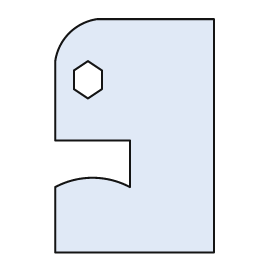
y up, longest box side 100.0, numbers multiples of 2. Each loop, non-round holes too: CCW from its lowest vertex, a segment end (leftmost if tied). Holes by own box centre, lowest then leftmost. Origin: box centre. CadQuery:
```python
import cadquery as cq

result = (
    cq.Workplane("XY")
    .moveTo(-34.0, -50.0)
    .lineTo(34.0, -50.0)
    .lineTo(34.0, 50.0)
    .lineTo(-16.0, 50.0)
    .threePointArc((-28.0, 44.0), (-34.0, 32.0))
    .lineTo(-34.0, -2.0)
    .lineTo(-2.0, -2.0)
    .lineTo(-2.0, -22.0)
    .threePointArc((-18.0, -18.0), (-34.0, -22.0))
    .close()
    .moveTo(-20.0, 16.0)
    .lineTo(-14.0, 20.0)
    .lineTo(-14.0, 28.0)
    .lineTo(-20.0, 32.0)
    .lineTo(-26.0, 28.0)
    .lineTo(-26.0, 20.0)
    .close()
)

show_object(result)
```